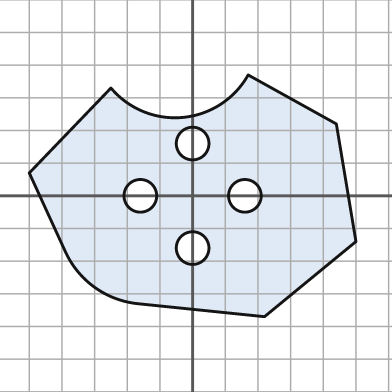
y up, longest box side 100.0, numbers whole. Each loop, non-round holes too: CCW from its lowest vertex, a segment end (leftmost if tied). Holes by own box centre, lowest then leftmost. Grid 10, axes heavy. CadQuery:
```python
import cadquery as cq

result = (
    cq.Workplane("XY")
    .moveTo(22.0, -37.0)
    .lineTo(50.0, -14.0)
    .lineTo(44.0, 22.0)
    .lineTo(17.0, 37.0)
    .threePointArc((-3.0, 24.0), (-25.0, 33.0))
    .lineTo(-50.0, 7.0)
    .lineTo(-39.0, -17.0)
    .threePointArc((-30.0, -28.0), (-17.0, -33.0))
    .close()
    .moveTo(0.0, -16.0)
    .circle(5.0)
    .moveTo(-16.0, 0.0)
    .circle(5.0)
    .moveTo(16.0, 0.0)
    .circle(5.0)
    .moveTo(0.0, 16.0)
    .circle(5.0)
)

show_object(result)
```